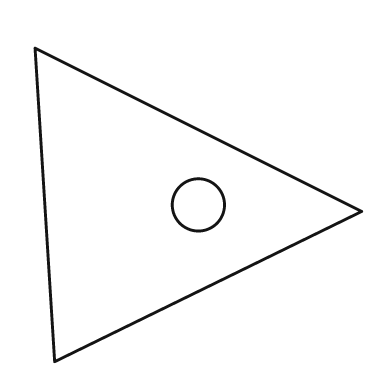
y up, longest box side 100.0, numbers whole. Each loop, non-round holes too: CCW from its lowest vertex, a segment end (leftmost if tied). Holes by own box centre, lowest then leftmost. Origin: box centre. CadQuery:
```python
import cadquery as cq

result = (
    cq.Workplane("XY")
    .moveTo(-44.0, -48.0)
    .lineTo(50.0, -2.0)
    .lineTo(-50.0, 48.0)
    .close()
    .moveTo(0.0, 0.0)
    .circle(8.0)
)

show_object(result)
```